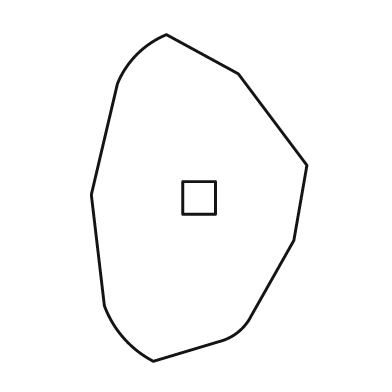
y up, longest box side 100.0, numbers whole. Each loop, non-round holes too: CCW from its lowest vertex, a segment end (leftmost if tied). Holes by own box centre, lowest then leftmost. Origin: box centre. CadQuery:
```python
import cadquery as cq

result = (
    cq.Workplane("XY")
    .moveTo(-14.0, -50.0)
    .lineTo(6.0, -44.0)
    .threePointArc((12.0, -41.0), (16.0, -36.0))
    .lineTo(29.0, -13.0)
    .lineTo(33.0, 10.0)
    .lineTo(12.0, 38.0)
    .lineTo(-10.0, 50.0)
    .threePointArc((-19.0, 44.0), (-25.0, 35.0))
    .lineTo(-33.0, 1.0)
    .lineTo(-29.0, -33.0)
    .threePointArc((-23.0, -43.0), (-14.0, -50.0))
    .close()
    .moveTo(-5.0, -5.0)
    .lineTo(5.0, -5.0)
    .lineTo(5.0, 5.0)
    .lineTo(-5.0, 5.0)
    .close()
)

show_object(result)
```